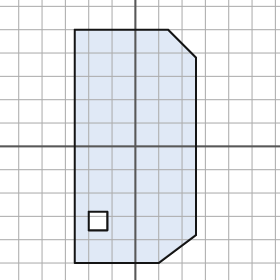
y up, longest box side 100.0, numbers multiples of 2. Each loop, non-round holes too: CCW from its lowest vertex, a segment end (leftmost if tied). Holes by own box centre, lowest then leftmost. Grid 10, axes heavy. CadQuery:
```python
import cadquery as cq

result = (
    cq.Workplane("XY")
    .moveTo(-26.0, -50.0)
    .lineTo(10.0, -50.0)
    .lineTo(26.0, -38.0)
    .lineTo(26.0, 38.0)
    .lineTo(14.0, 50.0)
    .lineTo(-26.0, 50.0)
    .close()
    .moveTo(-20.0, -36.0)
    .lineTo(-12.0, -36.0)
    .lineTo(-12.0, -28.0)
    .lineTo(-20.0, -28.0)
    .close()
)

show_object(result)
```